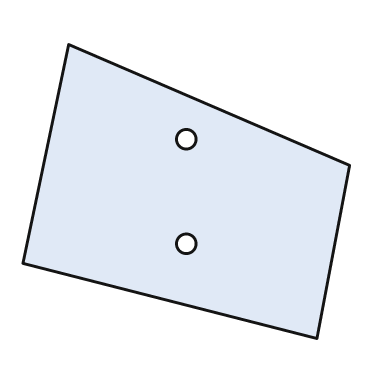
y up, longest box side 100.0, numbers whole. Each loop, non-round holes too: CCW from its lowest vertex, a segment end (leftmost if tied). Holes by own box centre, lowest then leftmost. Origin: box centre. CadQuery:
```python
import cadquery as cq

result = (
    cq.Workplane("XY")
    .moveTo(40.0, -45.0)
    .lineTo(50.0, 8.0)
    .lineTo(-36.0, 45.0)
    .lineTo(-50.0, -22.0)
    .close()
    .moveTo(0.0, -16.0)
    .circle(3.0)
    .moveTo(0.0, 16.0)
    .circle(3.0)
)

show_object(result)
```